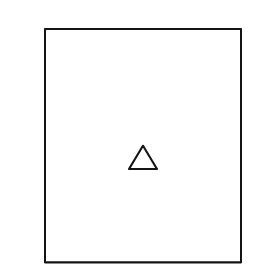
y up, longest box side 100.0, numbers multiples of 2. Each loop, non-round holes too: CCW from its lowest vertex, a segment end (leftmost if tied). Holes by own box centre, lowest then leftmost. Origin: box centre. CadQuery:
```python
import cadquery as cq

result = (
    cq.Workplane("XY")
    .moveTo(-42.0, -50.0)
    .lineTo(42.0, -50.0)
    .lineTo(42.0, 50.0)
    .lineTo(-42.0, 50.0)
    .close()
    .moveTo(-6.0, -10.0)
    .lineTo(6.0, -10.0)
    .lineTo(0.0, 0.0)
    .close()
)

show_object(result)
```